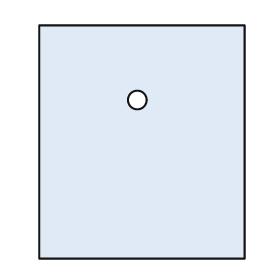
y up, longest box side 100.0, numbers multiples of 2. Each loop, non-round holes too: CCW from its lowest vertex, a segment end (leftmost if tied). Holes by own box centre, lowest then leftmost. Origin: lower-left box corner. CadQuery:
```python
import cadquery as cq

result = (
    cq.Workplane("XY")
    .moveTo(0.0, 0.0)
    .lineTo(88.0, 0.0)
    .lineTo(88.0, 100.0)
    .lineTo(0.0, 100.0)
    .close()
    .moveTo(42.0, 68.0)
    .circle(4.0)
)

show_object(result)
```